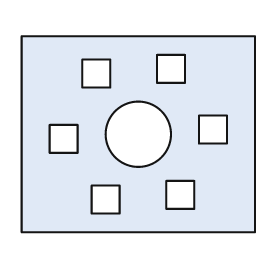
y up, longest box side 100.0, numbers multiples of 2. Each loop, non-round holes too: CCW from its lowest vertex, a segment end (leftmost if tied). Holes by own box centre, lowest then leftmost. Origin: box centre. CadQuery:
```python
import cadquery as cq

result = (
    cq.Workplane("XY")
    .moveTo(-50.0, -42.0)
    .lineTo(50.0, -42.0)
    .lineTo(50.0, 42.0)
    .lineTo(-50.0, 42.0)
    .close()
    .moveTo(-20.0, -34.0)
    .lineTo(-8.0, -34.0)
    .lineTo(-8.0, -22.0)
    .lineTo(-20.0, -22.0)
    .close()
    .moveTo(12.0, -32.0)
    .lineTo(24.0, -32.0)
    .lineTo(24.0, -20.0)
    .lineTo(12.0, -20.0)
    .close()
    .moveTo(-38.0, -8.0)
    .lineTo(-26.0, -8.0)
    .lineTo(-26.0, 4.0)
    .lineTo(-38.0, 4.0)
    .close()
    .moveTo(0.0, 0.0)
    .circle(14.0)
    .moveTo(26.0, -4.0)
    .lineTo(38.0, -4.0)
    .lineTo(38.0, 8.0)
    .lineTo(26.0, 8.0)
    .close()
    .moveTo(-24.0, 20.0)
    .lineTo(-12.0, 20.0)
    .lineTo(-12.0, 32.0)
    .lineTo(-24.0, 32.0)
    .close()
    .moveTo(8.0, 22.0)
    .lineTo(20.0, 22.0)
    .lineTo(20.0, 34.0)
    .lineTo(8.0, 34.0)
    .close()
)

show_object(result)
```